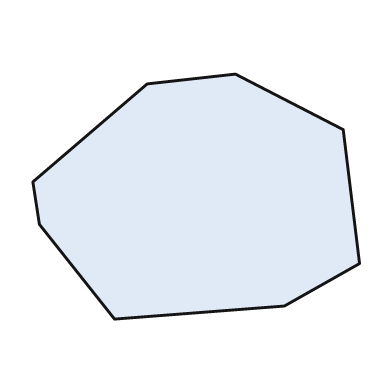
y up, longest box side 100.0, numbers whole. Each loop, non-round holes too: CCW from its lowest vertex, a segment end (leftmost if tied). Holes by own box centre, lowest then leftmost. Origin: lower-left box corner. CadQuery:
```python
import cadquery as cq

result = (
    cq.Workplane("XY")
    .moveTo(25.0, 0.0)
    .lineTo(77.0, 4.0)
    .lineTo(100.0, 17.0)
    .lineTo(95.0, 58.0)
    .lineTo(62.0, 75.0)
    .lineTo(35.0, 72.0)
    .lineTo(0.0, 42.0)
    .lineTo(2.0, 29.0)
    .close()
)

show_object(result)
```